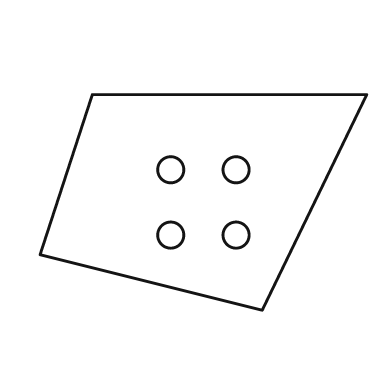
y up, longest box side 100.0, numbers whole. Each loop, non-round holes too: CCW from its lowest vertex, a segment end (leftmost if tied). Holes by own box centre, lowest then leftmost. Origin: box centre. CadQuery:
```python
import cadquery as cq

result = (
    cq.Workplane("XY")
    .moveTo(18.0, -33.0)
    .lineTo(50.0, 33.0)
    .lineTo(-34.0, 33.0)
    .lineTo(-50.0, -16.0)
    .close()
    .moveTo(-10.0, -10.0)
    .circle(4.0)
    .moveTo(10.0, -10.0)
    .circle(4.0)
    .moveTo(-10.0, 10.0)
    .circle(4.0)
    .moveTo(10.0, 10.0)
    .circle(4.0)
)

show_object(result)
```